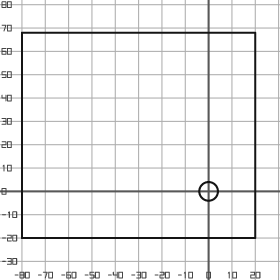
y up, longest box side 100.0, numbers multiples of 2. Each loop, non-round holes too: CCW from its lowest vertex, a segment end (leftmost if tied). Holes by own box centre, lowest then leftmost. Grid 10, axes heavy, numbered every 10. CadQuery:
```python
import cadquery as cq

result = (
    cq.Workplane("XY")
    .moveTo(-80.0, -20.0)
    .lineTo(20.0, -20.0)
    .lineTo(20.0, 68.0)
    .lineTo(-80.0, 68.0)
    .close()
    .moveTo(0.0, 0.0)
    .circle(4.0)
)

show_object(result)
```